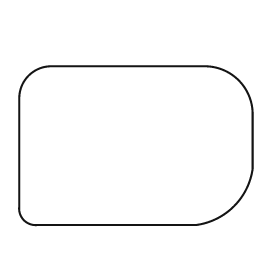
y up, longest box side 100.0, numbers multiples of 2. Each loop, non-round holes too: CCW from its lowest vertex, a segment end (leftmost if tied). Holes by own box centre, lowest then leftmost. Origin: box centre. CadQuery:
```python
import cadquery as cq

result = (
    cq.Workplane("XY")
    .moveTo(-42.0, -34.0)
    .lineTo(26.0, -34.0)
    .threePointArc((42.0, -26.0), (50.0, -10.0))
    .lineTo(50.0, 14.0)
    .threePointArc((44.0, 28.0), (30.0, 34.0))
    .lineTo(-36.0, 34.0)
    .threePointArc((-46.0, 30.0), (-50.0, 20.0))
    .lineTo(-50.0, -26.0)
    .threePointArc((-48.0, -32.0), (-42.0, -34.0))
    .close()
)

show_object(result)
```